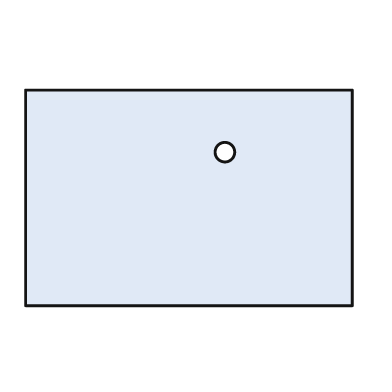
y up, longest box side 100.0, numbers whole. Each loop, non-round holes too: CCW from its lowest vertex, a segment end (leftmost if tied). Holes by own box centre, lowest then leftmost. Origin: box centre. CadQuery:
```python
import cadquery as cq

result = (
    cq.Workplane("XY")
    .moveTo(-50.0, -33.0)
    .lineTo(50.0, -33.0)
    .lineTo(50.0, 33.0)
    .lineTo(-50.0, 33.0)
    .close()
    .moveTo(11.0, 14.0)
    .circle(3.0)
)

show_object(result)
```